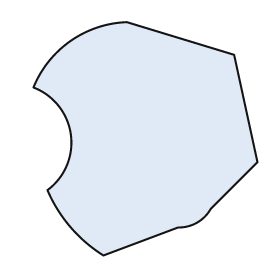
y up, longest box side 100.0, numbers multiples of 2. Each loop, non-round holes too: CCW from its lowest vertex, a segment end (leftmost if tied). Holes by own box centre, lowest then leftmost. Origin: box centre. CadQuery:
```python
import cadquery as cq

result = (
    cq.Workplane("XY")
    .moveTo(-18.0, -50.0)
    .lineTo(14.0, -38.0)
    .threePointArc((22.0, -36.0), (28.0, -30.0))
    .lineTo(48.0, -10.0)
    .lineTo(38.0, 36.0)
    .lineTo(-8.0, 50.0)
    .threePointArc((-32.0, 42.0), (-48.0, 22.0))
    .threePointArc((-32.0, 2.0), (-42.0, -22.0))
    .threePointArc((-32.0, -38.0), (-18.0, -50.0))
    .close()
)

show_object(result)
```